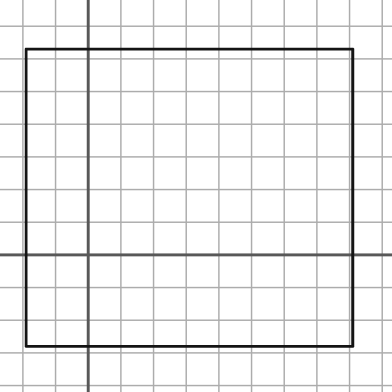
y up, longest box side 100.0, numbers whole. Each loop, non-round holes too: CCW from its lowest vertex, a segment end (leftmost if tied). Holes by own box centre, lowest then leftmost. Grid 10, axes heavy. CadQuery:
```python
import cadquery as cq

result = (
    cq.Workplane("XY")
    .moveTo(-19.0, -28.0)
    .lineTo(81.0, -28.0)
    .lineTo(81.0, 63.0)
    .lineTo(-19.0, 63.0)
    .close()
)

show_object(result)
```